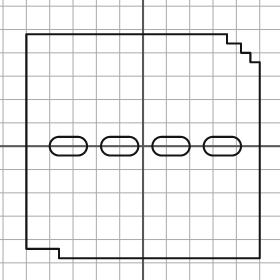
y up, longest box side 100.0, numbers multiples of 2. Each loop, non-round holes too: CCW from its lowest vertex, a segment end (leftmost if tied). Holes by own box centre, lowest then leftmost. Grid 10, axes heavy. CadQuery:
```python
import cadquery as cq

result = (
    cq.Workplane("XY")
    .moveTo(-36.0, -48.0)
    .lineTo(50.0, -48.0)
    .lineTo(50.0, 36.0)
    .lineTo(46.0, 36.0)
    .lineTo(46.0, 40.0)
    .lineTo(42.0, 40.0)
    .lineTo(42.0, 44.0)
    .lineTo(36.0, 44.0)
    .lineTo(36.0, 48.0)
    .lineTo(-50.0, 48.0)
    .lineTo(-50.0, -44.0)
    .lineTo(-36.0, -44.0)
    .close()
    .moveTo(-36.0, -4.0)
    .lineTo(-28.0, -4.0)
    .threePointArc((-24.0, 0.0), (-28.0, 4.0))
    .lineTo(-36.0, 4.0)
    .threePointArc((-40.0, 0.0), (-36.0, -4.0))
    .close()
    .moveTo(-14.0, -4.0)
    .lineTo(-6.0, -4.0)
    .threePointArc((-2.0, 0.0), (-6.0, 4.0))
    .lineTo(-14.0, 4.0)
    .threePointArc((-18.0, 0.0), (-14.0, -4.0))
    .close()
    .moveTo(8.0, -4.0)
    .lineTo(16.0, -4.0)
    .threePointArc((20.0, 0.0), (16.0, 4.0))
    .lineTo(8.0, 4.0)
    .threePointArc((4.0, 0.0), (8.0, -4.0))
    .close()
    .moveTo(30.0, -4.0)
    .lineTo(38.0, -4.0)
    .threePointArc((42.0, 0.0), (38.0, 4.0))
    .lineTo(30.0, 4.0)
    .threePointArc((26.0, 0.0), (30.0, -4.0))
    .close()
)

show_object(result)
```